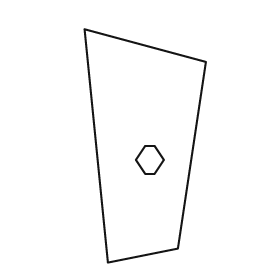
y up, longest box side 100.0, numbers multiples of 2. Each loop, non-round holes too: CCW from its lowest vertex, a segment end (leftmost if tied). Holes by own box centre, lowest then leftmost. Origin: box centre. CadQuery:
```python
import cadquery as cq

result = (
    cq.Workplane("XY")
    .moveTo(-16.0, -50.0)
    .lineTo(14.0, -44.0)
    .lineTo(26.0, 36.0)
    .lineTo(-26.0, 50.0)
    .close()
    .moveTo(0.0, -12.0)
    .lineTo(4.0, -12.0)
    .lineTo(8.0, -6.0)
    .lineTo(4.0, 0.0)
    .lineTo(0.0, 0.0)
    .lineTo(-4.0, -6.0)
    .close()
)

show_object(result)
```